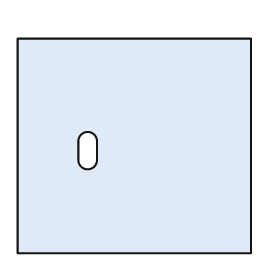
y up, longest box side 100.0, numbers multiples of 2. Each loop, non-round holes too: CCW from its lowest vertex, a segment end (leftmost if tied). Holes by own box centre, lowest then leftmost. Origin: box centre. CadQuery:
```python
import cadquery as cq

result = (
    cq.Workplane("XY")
    .moveTo(-50.0, -46.0)
    .lineTo(50.0, -46.0)
    .lineTo(50.0, 46.0)
    .lineTo(-50.0, 46.0)
    .close()
    .moveTo(-24.0, -6.0)
    .threePointArc((-20.0, -10.0), (-16.0, -6.0))
    .lineTo(-16.0, 2.0)
    .threePointArc((-20.0, 6.0), (-24.0, 2.0))
    .close()
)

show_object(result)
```